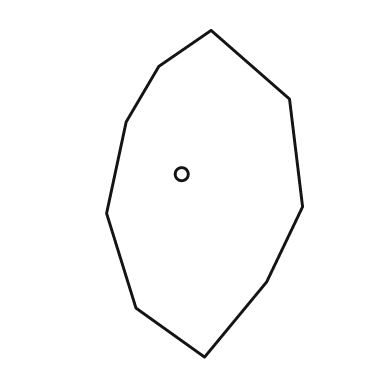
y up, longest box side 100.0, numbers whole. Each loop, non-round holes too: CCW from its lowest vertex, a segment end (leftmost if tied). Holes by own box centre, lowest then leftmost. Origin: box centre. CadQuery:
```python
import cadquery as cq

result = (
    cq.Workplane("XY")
    .moveTo(0.0, -50.0)
    .lineTo(19.0, -27.0)
    .lineTo(30.0, -4.0)
    .lineTo(26.0, 29.0)
    .lineTo(2.0, 50.0)
    .lineTo(-14.0, 39.0)
    .lineTo(-24.0, 22.0)
    .lineTo(-30.0, -6.0)
    .lineTo(-21.0, -35.0)
    .close()
    .moveTo(-7.0, 6.0)
    .circle(2.0)
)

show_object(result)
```